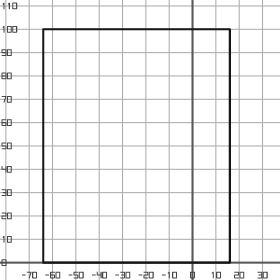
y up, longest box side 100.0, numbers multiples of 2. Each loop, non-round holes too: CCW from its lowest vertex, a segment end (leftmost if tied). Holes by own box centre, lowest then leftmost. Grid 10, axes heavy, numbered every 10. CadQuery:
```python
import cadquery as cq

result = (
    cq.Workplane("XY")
    .moveTo(-64.0, 0.0)
    .lineTo(16.0, 0.0)
    .lineTo(16.0, 100.0)
    .lineTo(-64.0, 100.0)
    .close()
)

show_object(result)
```